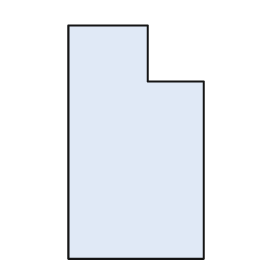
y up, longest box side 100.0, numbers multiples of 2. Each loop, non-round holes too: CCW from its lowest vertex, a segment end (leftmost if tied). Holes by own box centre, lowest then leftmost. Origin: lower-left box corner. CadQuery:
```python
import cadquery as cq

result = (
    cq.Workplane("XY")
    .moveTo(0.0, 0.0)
    .lineTo(58.0, 0.0)
    .lineTo(58.0, 76.0)
    .lineTo(34.0, 76.0)
    .lineTo(34.0, 100.0)
    .lineTo(0.0, 100.0)
    .close()
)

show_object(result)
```